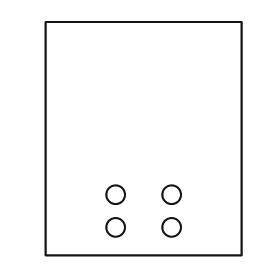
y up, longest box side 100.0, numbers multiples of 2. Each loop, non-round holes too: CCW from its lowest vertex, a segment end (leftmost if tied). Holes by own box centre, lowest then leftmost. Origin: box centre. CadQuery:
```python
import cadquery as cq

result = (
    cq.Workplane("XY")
    .moveTo(-42.0, -50.0)
    .lineTo(42.0, -50.0)
    .lineTo(42.0, 50.0)
    .lineTo(-42.0, 50.0)
    .close()
    .moveTo(-12.0, -38.0)
    .circle(4.0)
    .moveTo(12.0, -38.0)
    .circle(4.0)
    .moveTo(-12.0, -24.0)
    .circle(4.0)
    .moveTo(12.0, -24.0)
    .circle(4.0)
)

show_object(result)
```